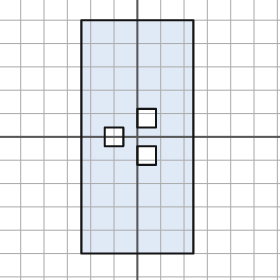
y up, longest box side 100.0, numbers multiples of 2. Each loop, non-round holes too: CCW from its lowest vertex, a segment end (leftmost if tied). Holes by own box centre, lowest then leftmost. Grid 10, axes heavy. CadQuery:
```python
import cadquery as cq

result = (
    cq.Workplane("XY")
    .moveTo(-24.0, -50.0)
    .lineTo(24.0, -50.0)
    .lineTo(24.0, 50.0)
    .lineTo(-24.0, 50.0)
    .close()
    .moveTo(0.0, -12.0)
    .lineTo(8.0, -12.0)
    .lineTo(8.0, -4.0)
    .lineTo(0.0, -4.0)
    .close()
    .moveTo(-14.0, -4.0)
    .lineTo(-6.0, -4.0)
    .lineTo(-6.0, 4.0)
    .lineTo(-14.0, 4.0)
    .close()
    .moveTo(0.0, 4.0)
    .lineTo(8.0, 4.0)
    .lineTo(8.0, 12.0)
    .lineTo(0.0, 12.0)
    .close()
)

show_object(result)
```